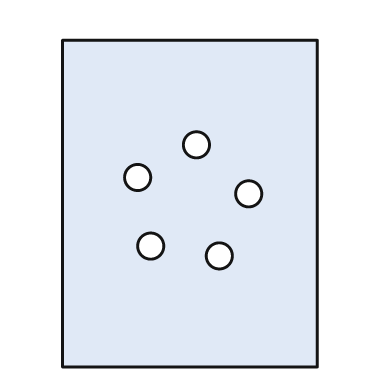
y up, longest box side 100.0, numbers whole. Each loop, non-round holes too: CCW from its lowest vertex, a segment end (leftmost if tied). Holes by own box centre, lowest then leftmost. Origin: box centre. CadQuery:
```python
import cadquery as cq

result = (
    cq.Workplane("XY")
    .moveTo(-39.0, -50.0)
    .lineTo(39.0, -50.0)
    .lineTo(39.0, 50.0)
    .lineTo(-39.0, 50.0)
    .close()
    .moveTo(9.0, -16.0)
    .circle(4.0)
    .moveTo(-12.0, -13.0)
    .circle(4.0)
    .moveTo(18.0, 3.0)
    .circle(4.0)
    .moveTo(-16.0, 8.0)
    .circle(4.0)
    .moveTo(2.0, 18.0)
    .circle(4.0)
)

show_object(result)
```